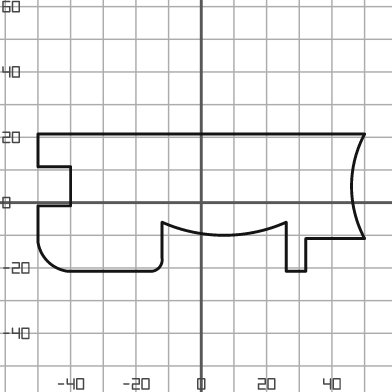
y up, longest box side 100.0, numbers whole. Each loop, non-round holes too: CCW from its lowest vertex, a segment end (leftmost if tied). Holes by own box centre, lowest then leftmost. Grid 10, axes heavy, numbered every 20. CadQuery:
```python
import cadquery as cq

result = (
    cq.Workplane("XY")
    .moveTo(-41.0, -21.0)
    .lineTo(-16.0, -21.0)
    .threePointArc((-13.0, -20.0), (-12.0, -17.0))
    .lineTo(-12.0, -6.0)
    .threePointArc((7.0, -10.0), (26.0, -6.0))
    .lineTo(26.0, -21.0)
    .lineTo(32.0, -21.0)
    .lineTo(32.0, -11.0)
    .lineTo(50.0, -11.0)
    .threePointArc((46.0, 5.0), (50.0, 21.0))
    .lineTo(-50.0, 21.0)
    .lineTo(-50.0, 11.0)
    .lineTo(-40.0, 11.0)
    .lineTo(-40.0, -1.0)
    .lineTo(-50.0, -1.0)
    .lineTo(-50.0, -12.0)
    .threePointArc((-47.0, -18.0), (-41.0, -21.0))
    .close()
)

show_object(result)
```